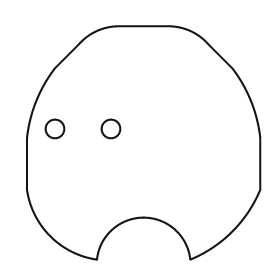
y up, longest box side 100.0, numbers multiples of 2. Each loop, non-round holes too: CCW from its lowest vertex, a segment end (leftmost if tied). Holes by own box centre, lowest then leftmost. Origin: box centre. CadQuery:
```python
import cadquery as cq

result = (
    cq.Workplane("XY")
    .moveTo(-20.0, -50.0)
    .threePointArc((0.0, -32.0), (20.0, -50.0))
    .threePointArc((38.0, -38.0), (50.0, -20.0))
    .lineTo(50.0, 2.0)
    .threePointArc((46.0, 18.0), (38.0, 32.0))
    .lineTo(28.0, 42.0)
    .threePointArc((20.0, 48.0), (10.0, 50.0))
    .lineTo(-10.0, 50.0)
    .threePointArc((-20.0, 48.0), (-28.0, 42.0))
    .lineTo(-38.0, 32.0)
    .threePointArc((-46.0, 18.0), (-50.0, 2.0))
    .lineTo(-50.0, -20.0)
    .threePointArc((-40.0, -40.0), (-20.0, -50.0))
    .close()
    .moveTo(-38.0, 6.0)
    .circle(4.0)
    .moveTo(-14.0, 6.0)
    .circle(4.0)
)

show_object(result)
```